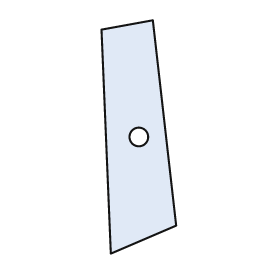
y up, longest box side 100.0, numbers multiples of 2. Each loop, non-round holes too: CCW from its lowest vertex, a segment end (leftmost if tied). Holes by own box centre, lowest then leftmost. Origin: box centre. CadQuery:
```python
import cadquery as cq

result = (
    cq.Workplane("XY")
    .moveTo(-12.0, -50.0)
    .lineTo(16.0, -38.0)
    .lineTo(6.0, 50.0)
    .lineTo(-16.0, 46.0)
    .close()
    .moveTo(0.0, 0.0)
    .circle(4.0)
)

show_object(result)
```